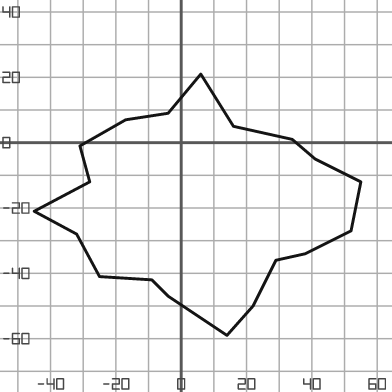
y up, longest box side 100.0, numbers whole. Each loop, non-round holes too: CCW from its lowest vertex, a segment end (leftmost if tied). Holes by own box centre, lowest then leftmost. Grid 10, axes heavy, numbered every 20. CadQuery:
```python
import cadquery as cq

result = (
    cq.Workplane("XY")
    .moveTo(14.0, -59.0)
    .lineTo(22.0, -50.0)
    .lineTo(29.0, -36.0)
    .lineTo(38.0, -34.0)
    .lineTo(52.0, -27.0)
    .lineTo(55.0, -12.0)
    .lineTo(41.0, -5.0)
    .lineTo(34.0, 1.0)
    .lineTo(16.0, 5.0)
    .lineTo(6.0, 21.0)
    .lineTo(-4.0, 9.0)
    .lineTo(-17.0, 7.0)
    .lineTo(-31.0, -1.0)
    .lineTo(-28.0, -12.0)
    .lineTo(-45.0, -21.0)
    .lineTo(-32.0, -28.0)
    .lineTo(-25.0, -41.0)
    .lineTo(-9.0, -42.0)
    .lineTo(-4.0, -47.0)
    .close()
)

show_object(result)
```